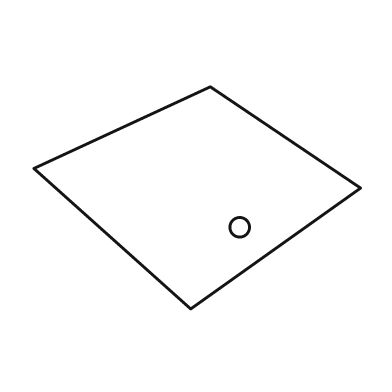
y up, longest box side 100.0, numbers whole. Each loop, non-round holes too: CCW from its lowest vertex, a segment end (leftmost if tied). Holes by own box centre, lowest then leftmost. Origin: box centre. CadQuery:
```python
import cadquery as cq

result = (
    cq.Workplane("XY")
    .moveTo(-2.0, -34.0)
    .lineTo(50.0, 3.0)
    .lineTo(4.0, 34.0)
    .lineTo(-50.0, 9.0)
    .close()
    .moveTo(13.0, -9.0)
    .circle(3.0)
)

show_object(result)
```